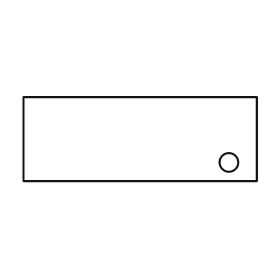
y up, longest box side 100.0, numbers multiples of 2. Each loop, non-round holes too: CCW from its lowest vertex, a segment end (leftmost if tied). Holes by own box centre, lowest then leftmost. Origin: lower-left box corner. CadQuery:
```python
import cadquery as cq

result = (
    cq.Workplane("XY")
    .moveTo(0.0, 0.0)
    .lineTo(100.0, 0.0)
    .lineTo(100.0, 36.0)
    .lineTo(0.0, 36.0)
    .close()
    .moveTo(88.0, 8.0)
    .circle(4.0)
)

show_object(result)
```